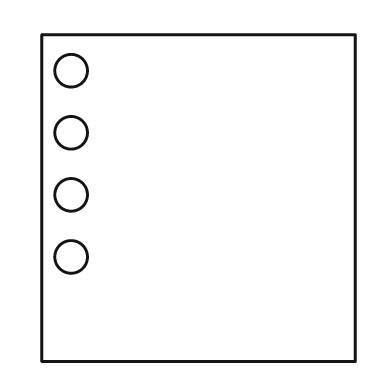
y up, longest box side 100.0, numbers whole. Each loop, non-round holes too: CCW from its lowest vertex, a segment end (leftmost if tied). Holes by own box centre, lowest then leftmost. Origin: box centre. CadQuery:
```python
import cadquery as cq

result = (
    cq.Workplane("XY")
    .moveTo(-48.0, -50.0)
    .lineTo(48.0, -50.0)
    .lineTo(48.0, 50.0)
    .lineTo(-48.0, 50.0)
    .close()
    .moveTo(-39.0, -18.0)
    .circle(5.0)
    .moveTo(-39.0, 1.0)
    .circle(5.0)
    .moveTo(-39.0, 20.0)
    .circle(5.0)
    .moveTo(-39.0, 39.0)
    .circle(5.0)
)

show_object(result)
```